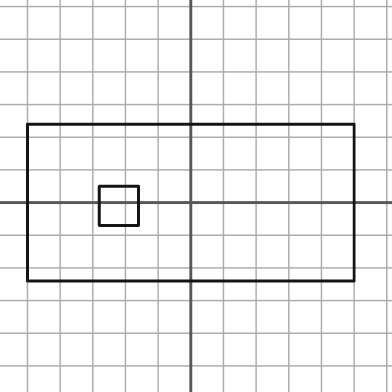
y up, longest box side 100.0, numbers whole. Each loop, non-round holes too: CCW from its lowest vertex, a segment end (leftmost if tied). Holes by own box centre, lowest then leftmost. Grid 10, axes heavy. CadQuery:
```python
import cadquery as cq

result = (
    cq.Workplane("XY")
    .moveTo(-50.0, -24.0)
    .lineTo(50.0, -24.0)
    .lineTo(50.0, 24.0)
    .lineTo(-50.0, 24.0)
    .close()
    .moveTo(-28.0, -7.0)
    .lineTo(-16.0, -7.0)
    .lineTo(-16.0, 5.0)
    .lineTo(-28.0, 5.0)
    .close()
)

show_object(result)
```